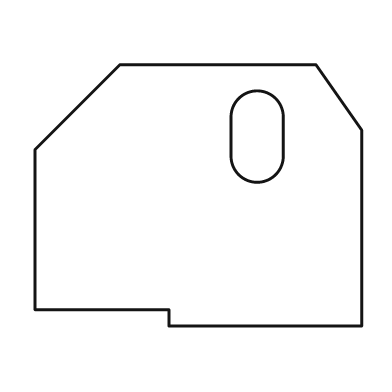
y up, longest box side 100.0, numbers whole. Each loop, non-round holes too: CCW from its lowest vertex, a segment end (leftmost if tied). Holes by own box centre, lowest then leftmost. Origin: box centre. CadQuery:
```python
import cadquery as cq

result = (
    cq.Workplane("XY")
    .moveTo(-9.0, -40.0)
    .lineTo(50.0, -40.0)
    .lineTo(50.0, 20.0)
    .lineTo(36.0, 40.0)
    .lineTo(-24.0, 40.0)
    .lineTo(-50.0, 14.0)
    .lineTo(-50.0, -35.0)
    .lineTo(-9.0, -35.0)
    .close()
    .moveTo(10.0, 12.0)
    .threePointArc((18.0, 4.0), (26.0, 12.0))
    .lineTo(26.0, 24.0)
    .threePointArc((18.0, 32.0), (10.0, 24.0))
    .close()
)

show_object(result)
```